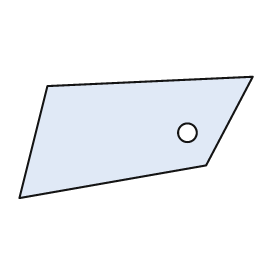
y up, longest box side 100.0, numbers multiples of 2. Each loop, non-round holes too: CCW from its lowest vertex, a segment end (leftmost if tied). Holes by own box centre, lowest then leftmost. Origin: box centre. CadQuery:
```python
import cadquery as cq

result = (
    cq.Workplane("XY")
    .moveTo(-50.0, -26.0)
    .lineTo(30.0, -12.0)
    .lineTo(50.0, 26.0)
    .lineTo(-38.0, 22.0)
    .close()
    .moveTo(22.0, 2.0)
    .circle(4.0)
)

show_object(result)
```